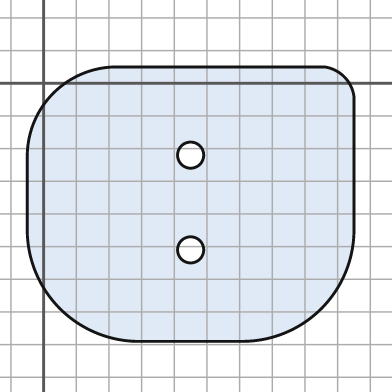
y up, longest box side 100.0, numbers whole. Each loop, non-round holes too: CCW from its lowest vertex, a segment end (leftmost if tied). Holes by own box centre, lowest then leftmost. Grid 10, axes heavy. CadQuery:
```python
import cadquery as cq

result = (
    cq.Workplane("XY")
    .moveTo(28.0, -79.0)
    .lineTo(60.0, -79.0)
    .threePointArc((85.0, -69.0), (95.0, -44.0))
    .lineTo(95.0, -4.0)
    .threePointArc((92.0, 2.0), (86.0, 5.0))
    .lineTo(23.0, 5.0)
    .threePointArc((3.0, -3.0), (-5.0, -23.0))
    .lineTo(-5.0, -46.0)
    .threePointArc((5.0, -69.0), (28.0, -79.0))
    .close()
    .moveTo(45.0, -51.0)
    .circle(4.0)
    .moveTo(45.0, -22.0)
    .circle(4.0)
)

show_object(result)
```